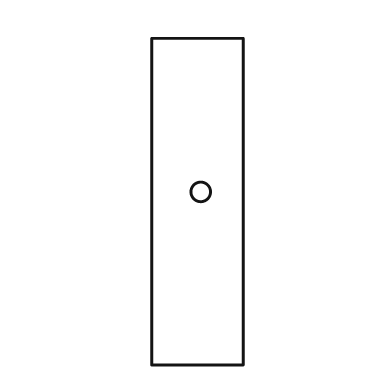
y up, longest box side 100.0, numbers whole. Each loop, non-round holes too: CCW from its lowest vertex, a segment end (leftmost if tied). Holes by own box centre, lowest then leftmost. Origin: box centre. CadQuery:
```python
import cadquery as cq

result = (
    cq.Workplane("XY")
    .moveTo(-14.0, -50.0)
    .lineTo(14.0, -50.0)
    .lineTo(14.0, 50.0)
    .lineTo(-14.0, 50.0)
    .close()
    .moveTo(1.0, 3.0)
    .circle(3.0)
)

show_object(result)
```